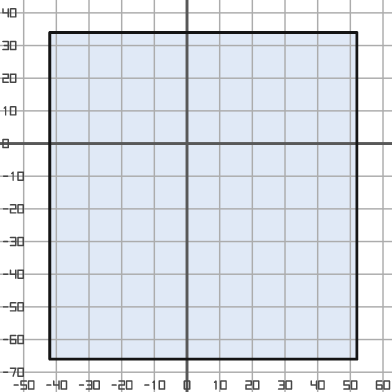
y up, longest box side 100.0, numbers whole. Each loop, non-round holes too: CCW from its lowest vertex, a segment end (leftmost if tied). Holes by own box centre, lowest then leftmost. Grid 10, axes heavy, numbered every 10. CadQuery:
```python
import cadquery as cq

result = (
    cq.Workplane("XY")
    .moveTo(-42.0, -66.0)
    .lineTo(52.0, -66.0)
    .lineTo(52.0, 34.0)
    .lineTo(-42.0, 34.0)
    .close()
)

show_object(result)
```